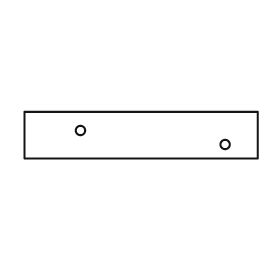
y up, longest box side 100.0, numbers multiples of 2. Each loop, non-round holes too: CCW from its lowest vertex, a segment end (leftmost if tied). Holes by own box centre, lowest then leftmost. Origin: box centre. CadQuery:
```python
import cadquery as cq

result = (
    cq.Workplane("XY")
    .moveTo(-50.0, -10.0)
    .lineTo(50.0, -10.0)
    .lineTo(50.0, 10.0)
    .lineTo(-50.0, 10.0)
    .close()
    .moveTo(36.0, -4.0)
    .circle(2.0)
    .moveTo(-26.0, 2.0)
    .circle(2.0)
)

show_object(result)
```